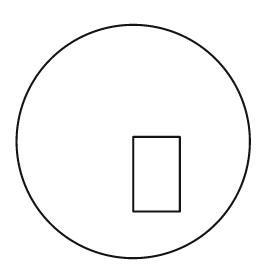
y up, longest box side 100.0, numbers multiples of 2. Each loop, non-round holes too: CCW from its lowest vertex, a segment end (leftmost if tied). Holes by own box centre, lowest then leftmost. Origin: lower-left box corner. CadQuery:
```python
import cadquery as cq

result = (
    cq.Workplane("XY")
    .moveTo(50.0, 50.0)
    .circle(50.0)
    .moveTo(50.0, 20.0)
    .lineTo(70.0, 20.0)
    .lineTo(70.0, 52.0)
    .lineTo(50.0, 52.0)
    .close()
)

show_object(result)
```